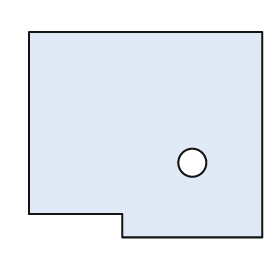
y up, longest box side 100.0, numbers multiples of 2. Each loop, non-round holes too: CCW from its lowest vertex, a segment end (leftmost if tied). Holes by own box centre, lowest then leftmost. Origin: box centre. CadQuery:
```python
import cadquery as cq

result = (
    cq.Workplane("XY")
    .moveTo(-10.0, -44.0)
    .lineTo(50.0, -44.0)
    .lineTo(50.0, 44.0)
    .lineTo(-50.0, 44.0)
    .lineTo(-50.0, -34.0)
    .lineTo(-10.0, -34.0)
    .close()
    .moveTo(20.0, -12.0)
    .circle(6.0)
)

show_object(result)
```